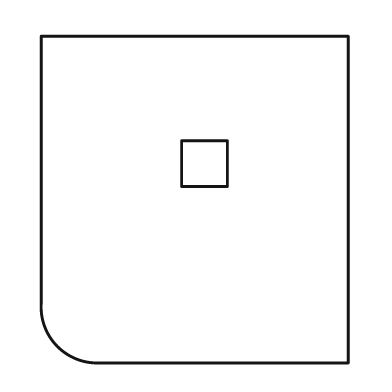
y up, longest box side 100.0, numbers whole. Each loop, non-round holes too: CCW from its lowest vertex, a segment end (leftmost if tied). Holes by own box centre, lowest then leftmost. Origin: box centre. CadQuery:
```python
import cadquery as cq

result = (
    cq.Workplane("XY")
    .moveTo(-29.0, -50.0)
    .lineTo(47.0, -50.0)
    .lineTo(47.0, 50.0)
    .lineTo(-47.0, 50.0)
    .lineTo(-47.0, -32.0)
    .threePointArc((-42.0, -45.0), (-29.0, -50.0))
    .close()
    .moveTo(-4.0, 4.0)
    .lineTo(10.0, 4.0)
    .lineTo(10.0, 18.0)
    .lineTo(-4.0, 18.0)
    .close()
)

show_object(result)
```